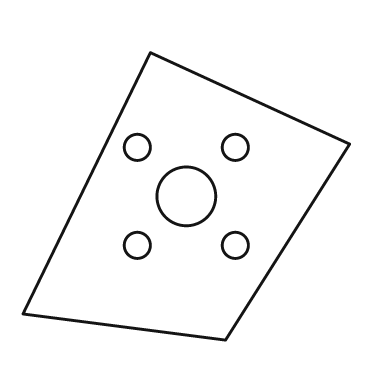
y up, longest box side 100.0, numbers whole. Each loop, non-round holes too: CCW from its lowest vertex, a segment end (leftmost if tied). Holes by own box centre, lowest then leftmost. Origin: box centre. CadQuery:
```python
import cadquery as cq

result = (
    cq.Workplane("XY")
    .moveTo(12.0, -44.0)
    .lineTo(50.0, 16.0)
    .lineTo(-11.0, 44.0)
    .lineTo(-50.0, -36.0)
    .close()
    .moveTo(-15.0, -15.0)
    .circle(4.0)
    .moveTo(15.0, -15.0)
    .circle(4.0)
    .moveTo(0.0, 0.0)
    .circle(9.0)
    .moveTo(-15.0, 15.0)
    .circle(4.0)
    .moveTo(15.0, 15.0)
    .circle(4.0)
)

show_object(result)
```